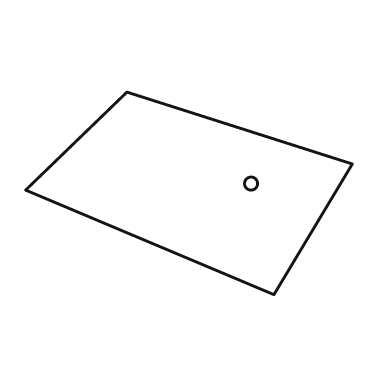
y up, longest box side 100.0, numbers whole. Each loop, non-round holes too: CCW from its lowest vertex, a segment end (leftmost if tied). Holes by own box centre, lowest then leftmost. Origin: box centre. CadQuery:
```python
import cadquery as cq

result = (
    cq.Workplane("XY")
    .moveTo(26.0, -31.0)
    .lineTo(50.0, 9.0)
    .lineTo(-19.0, 31.0)
    .lineTo(-50.0, 1.0)
    .close()
    .moveTo(19.0, 3.0)
    .circle(2.0)
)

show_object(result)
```